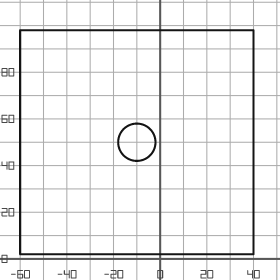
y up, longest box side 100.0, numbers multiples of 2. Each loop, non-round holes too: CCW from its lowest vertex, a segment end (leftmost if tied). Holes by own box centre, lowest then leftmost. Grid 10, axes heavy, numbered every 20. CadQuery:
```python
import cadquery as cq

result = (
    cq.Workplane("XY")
    .moveTo(-60.0, 2.0)
    .lineTo(40.0, 2.0)
    .lineTo(40.0, 98.0)
    .lineTo(-60.0, 98.0)
    .close()
    .moveTo(-10.0, 50.0)
    .circle(8.0)
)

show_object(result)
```